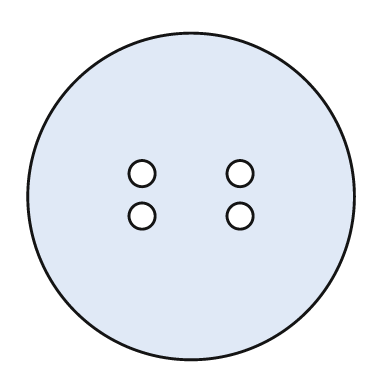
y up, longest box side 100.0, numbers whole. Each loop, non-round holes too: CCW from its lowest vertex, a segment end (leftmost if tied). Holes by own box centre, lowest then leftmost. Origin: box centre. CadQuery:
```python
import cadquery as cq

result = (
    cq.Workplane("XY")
    .moveTo(0.0, 0.0)
    .circle(50.0)
    .moveTo(-15.0, -6.0)
    .circle(4.0)
    .moveTo(15.0, -6.0)
    .circle(4.0)
    .moveTo(-15.0, 7.0)
    .circle(4.0)
    .moveTo(15.0, 7.0)
    .circle(4.0)
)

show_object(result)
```